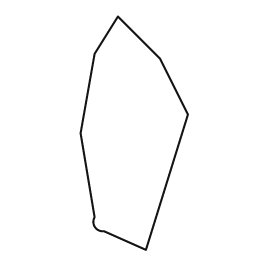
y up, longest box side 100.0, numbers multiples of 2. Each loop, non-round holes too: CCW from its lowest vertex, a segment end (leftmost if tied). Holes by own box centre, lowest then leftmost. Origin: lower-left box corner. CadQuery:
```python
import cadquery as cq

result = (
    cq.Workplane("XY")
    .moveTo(28.0, 0.0)
    .lineTo(46.0, 58.0)
    .lineTo(34.0, 82.0)
    .lineTo(16.0, 100.0)
    .lineTo(6.0, 84.0)
    .lineTo(0.0, 50.0)
    .lineTo(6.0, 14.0)
    .threePointArc((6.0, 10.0), (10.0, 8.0))
    .close()
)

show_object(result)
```